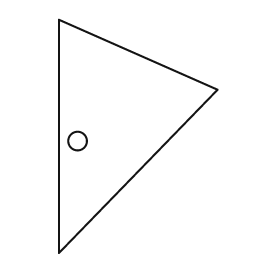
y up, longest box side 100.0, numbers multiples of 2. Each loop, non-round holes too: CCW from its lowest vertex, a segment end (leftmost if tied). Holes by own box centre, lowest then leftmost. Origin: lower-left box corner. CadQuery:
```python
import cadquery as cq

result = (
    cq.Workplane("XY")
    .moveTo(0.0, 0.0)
    .lineTo(68.0, 70.0)
    .lineTo(0.0, 100.0)
    .close()
    .moveTo(8.0, 48.0)
    .circle(4.0)
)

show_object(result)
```